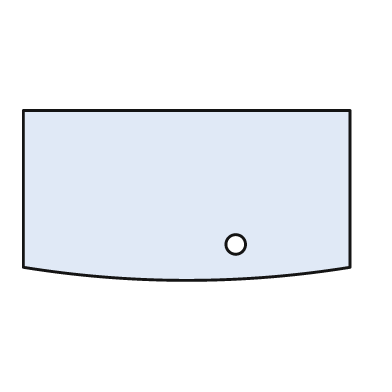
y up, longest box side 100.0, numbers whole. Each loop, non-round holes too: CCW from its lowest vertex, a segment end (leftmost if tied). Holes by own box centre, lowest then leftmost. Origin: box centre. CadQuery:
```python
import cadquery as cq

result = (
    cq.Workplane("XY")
    .moveTo(-50.0, -22.0)
    .threePointArc((0.0, -26.0), (50.0, -22.0))
    .lineTo(50.0, 26.0)
    .lineTo(-50.0, 26.0)
    .close()
    .moveTo(15.0, -15.0)
    .circle(3.0)
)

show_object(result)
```